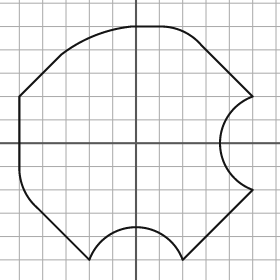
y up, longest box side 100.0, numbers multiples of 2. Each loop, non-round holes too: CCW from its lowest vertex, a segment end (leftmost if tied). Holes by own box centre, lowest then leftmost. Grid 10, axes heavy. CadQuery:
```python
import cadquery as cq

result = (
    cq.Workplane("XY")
    .moveTo(-20.0, -50.0)
    .threePointArc((0.0, -36.0), (20.0, -50.0))
    .lineTo(50.0, -20.0)
    .threePointArc((36.0, 0.0), (50.0, 20.0))
    .lineTo(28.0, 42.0)
    .threePointArc((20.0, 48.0), (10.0, 50.0))
    .lineTo(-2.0, 50.0)
    .threePointArc((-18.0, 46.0), (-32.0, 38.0))
    .lineTo(-50.0, 20.0)
    .lineTo(-50.0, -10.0)
    .threePointArc((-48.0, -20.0), (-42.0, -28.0))
    .close()
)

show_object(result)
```